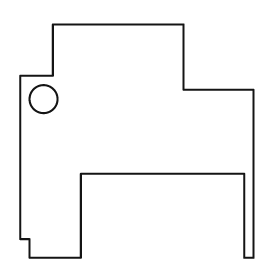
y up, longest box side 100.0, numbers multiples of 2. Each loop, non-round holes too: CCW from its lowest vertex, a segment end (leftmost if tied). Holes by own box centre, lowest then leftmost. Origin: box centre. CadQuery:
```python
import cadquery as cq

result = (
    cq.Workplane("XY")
    .moveTo(-46.0, -50.0)
    .lineTo(-24.0, -50.0)
    .lineTo(-24.0, -14.0)
    .lineTo(46.0, -14.0)
    .lineTo(46.0, -50.0)
    .lineTo(50.0, -50.0)
    .lineTo(50.0, 22.0)
    .lineTo(20.0, 22.0)
    .lineTo(20.0, 50.0)
    .lineTo(-36.0, 50.0)
    .lineTo(-36.0, 28.0)
    .lineTo(-50.0, 28.0)
    .lineTo(-50.0, -42.0)
    .lineTo(-46.0, -42.0)
    .close()
    .moveTo(-40.0, 18.0)
    .circle(6.0)
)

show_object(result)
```